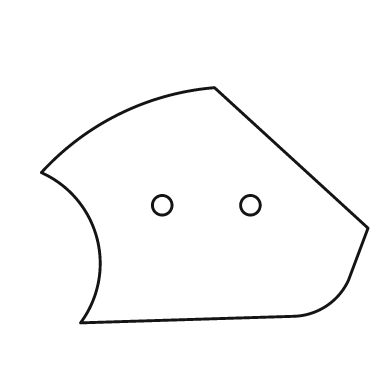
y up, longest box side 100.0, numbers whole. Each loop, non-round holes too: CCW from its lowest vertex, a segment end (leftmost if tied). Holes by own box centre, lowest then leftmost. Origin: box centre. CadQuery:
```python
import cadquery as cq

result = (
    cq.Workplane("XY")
    .moveTo(-38.0, -36.0)
    .lineTo(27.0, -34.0)
    .threePointArc((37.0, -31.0), (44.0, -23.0))
    .lineTo(50.0, -7.0)
    .lineTo(3.0, 36.0)
    .threePointArc((-26.0, 28.0), (-50.0, 10.0))
    .threePointArc((-33.0, -10.0), (-38.0, -36.0))
    .close()
    .moveTo(-13.0, 0.0)
    .circle(3.0)
    .moveTo(14.0, 0.0)
    .circle(3.0)
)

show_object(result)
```